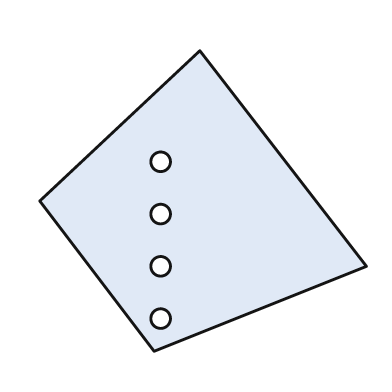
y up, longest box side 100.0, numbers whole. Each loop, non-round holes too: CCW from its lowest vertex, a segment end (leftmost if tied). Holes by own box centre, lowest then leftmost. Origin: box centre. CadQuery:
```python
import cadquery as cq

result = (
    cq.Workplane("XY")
    .moveTo(-15.0, -46.0)
    .lineTo(50.0, -20.0)
    .lineTo(-1.0, 46.0)
    .lineTo(-50.0, 0.0)
    .close()
    .moveTo(-13.0, -36.0)
    .circle(3.0)
    .moveTo(-13.0, -20.0)
    .circle(3.0)
    .moveTo(-13.0, -4.0)
    .circle(3.0)
    .moveTo(-13.0, 12.0)
    .circle(3.0)
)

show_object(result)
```